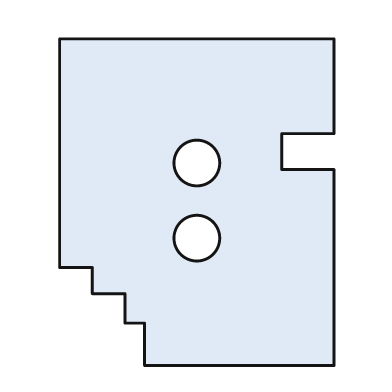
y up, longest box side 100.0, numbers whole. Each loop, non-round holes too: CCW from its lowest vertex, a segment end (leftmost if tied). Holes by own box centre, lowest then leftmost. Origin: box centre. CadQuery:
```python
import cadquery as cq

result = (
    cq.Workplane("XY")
    .moveTo(-16.0, -50.0)
    .lineTo(42.0, -50.0)
    .lineTo(42.0, 10.0)
    .lineTo(26.0, 10.0)
    .lineTo(26.0, 21.0)
    .lineTo(42.0, 21.0)
    .lineTo(42.0, 50.0)
    .lineTo(-42.0, 50.0)
    .lineTo(-42.0, -20.0)
    .lineTo(-32.0, -20.0)
    .lineTo(-32.0, -28.0)
    .lineTo(-22.0, -28.0)
    .lineTo(-22.0, -37.0)
    .lineTo(-16.0, -37.0)
    .close()
    .moveTo(0.0, -11.0)
    .circle(7.0)
    .moveTo(0.0, 12.0)
    .circle(7.0)
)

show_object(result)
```